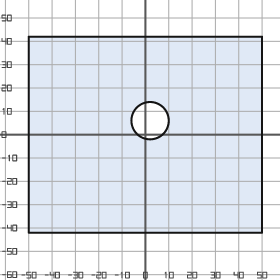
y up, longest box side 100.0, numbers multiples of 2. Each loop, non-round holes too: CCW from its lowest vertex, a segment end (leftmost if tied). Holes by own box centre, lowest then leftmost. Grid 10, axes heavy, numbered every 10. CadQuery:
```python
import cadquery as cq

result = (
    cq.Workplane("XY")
    .moveTo(-50.0, -42.0)
    .lineTo(50.0, -42.0)
    .lineTo(50.0, 42.0)
    .lineTo(-50.0, 42.0)
    .close()
    .moveTo(2.0, 6.0)
    .circle(8.0)
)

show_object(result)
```